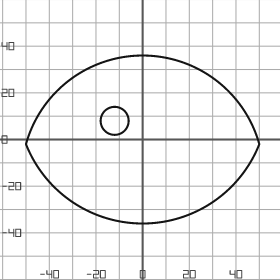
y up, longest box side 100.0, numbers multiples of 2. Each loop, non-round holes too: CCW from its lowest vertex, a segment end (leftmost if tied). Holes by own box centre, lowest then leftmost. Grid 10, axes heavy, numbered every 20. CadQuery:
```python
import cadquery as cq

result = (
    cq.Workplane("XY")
    .moveTo(-50.0, -2.0)
    .threePointArc((0.0, -36.0), (50.0, -2.0))
    .threePointArc((0.0, 36.0), (-50.0, -2.0))
    .close()
    .moveTo(-12.0, 8.0)
    .circle(6.0)
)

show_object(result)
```